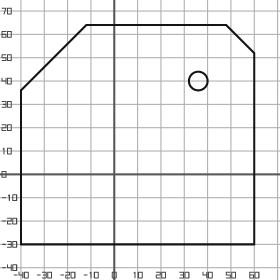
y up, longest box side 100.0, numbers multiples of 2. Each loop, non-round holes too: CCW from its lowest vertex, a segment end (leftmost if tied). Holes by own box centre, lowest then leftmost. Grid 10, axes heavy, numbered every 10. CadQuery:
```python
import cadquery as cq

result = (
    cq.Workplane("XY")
    .moveTo(-40.0, -30.0)
    .lineTo(60.0, -30.0)
    .lineTo(60.0, 52.0)
    .lineTo(48.0, 64.0)
    .lineTo(-12.0, 64.0)
    .lineTo(-40.0, 36.0)
    .close()
    .moveTo(36.0, 40.0)
    .circle(4.0)
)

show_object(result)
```